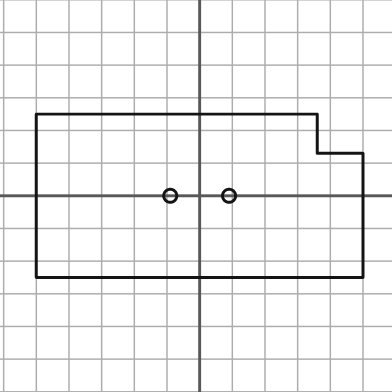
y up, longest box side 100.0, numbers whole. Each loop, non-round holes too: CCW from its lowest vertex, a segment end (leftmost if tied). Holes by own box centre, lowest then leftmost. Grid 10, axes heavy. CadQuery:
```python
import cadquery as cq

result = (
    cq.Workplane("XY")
    .moveTo(-50.0, -25.0)
    .lineTo(50.0, -25.0)
    .lineTo(50.0, 13.0)
    .lineTo(36.0, 13.0)
    .lineTo(36.0, 25.0)
    .lineTo(-50.0, 25.0)
    .close()
    .moveTo(-9.0, 0.0)
    .circle(2.0)
    .moveTo(9.0, 0.0)
    .circle(2.0)
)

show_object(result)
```